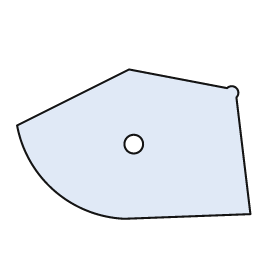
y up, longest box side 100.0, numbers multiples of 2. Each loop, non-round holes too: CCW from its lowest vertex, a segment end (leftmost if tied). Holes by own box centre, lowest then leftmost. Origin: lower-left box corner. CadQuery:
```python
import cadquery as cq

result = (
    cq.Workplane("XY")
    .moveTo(46.0, 0.0)
    .lineTo(100.0, 2.0)
    .lineTo(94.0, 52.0)
    .threePointArc((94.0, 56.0), (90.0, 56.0))
    .lineTo(48.0, 64.0)
    .lineTo(0.0, 40.0)
    .threePointArc((16.0, 12.0), (46.0, 0.0))
    .close()
    .moveTo(50.0, 32.0)
    .circle(4.0)
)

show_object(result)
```